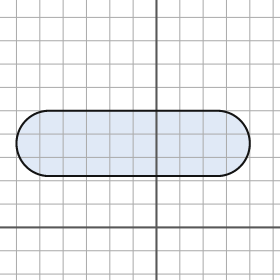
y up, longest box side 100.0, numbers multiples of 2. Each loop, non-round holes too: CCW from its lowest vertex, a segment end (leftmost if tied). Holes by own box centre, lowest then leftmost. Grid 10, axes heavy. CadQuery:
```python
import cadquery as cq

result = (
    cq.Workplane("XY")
    .moveTo(-46.0, 22.0)
    .lineTo(26.0, 22.0)
    .threePointArc((40.0, 36.0), (26.0, 50.0))
    .lineTo(-46.0, 50.0)
    .threePointArc((-60.0, 36.0), (-46.0, 22.0))
    .close()
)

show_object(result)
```